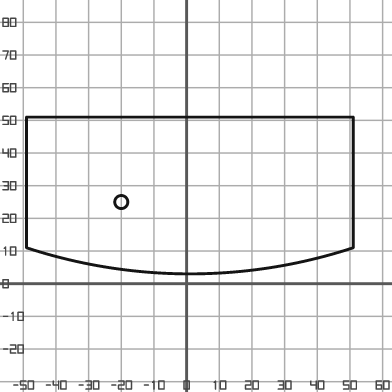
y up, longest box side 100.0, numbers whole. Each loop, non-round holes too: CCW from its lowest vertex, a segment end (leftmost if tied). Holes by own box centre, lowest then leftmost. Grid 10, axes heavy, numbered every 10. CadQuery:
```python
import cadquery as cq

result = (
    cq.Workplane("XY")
    .moveTo(-49.0, 11.0)
    .threePointArc((1.0, 3.0), (51.0, 11.0))
    .lineTo(51.0, 51.0)
    .lineTo(-49.0, 51.0)
    .close()
    .moveTo(-20.0, 25.0)
    .circle(2.0)
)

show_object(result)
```